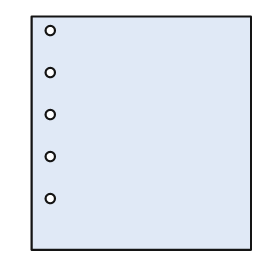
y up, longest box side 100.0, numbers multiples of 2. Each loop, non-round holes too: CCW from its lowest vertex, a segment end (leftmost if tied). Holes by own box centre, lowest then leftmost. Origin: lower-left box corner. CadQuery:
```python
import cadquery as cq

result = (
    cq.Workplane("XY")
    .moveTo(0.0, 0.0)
    .lineTo(94.0, 0.0)
    .lineTo(94.0, 100.0)
    .lineTo(0.0, 100.0)
    .close()
    .moveTo(8.0, 22.0)
    .circle(2.0)
    .moveTo(8.0, 40.0)
    .circle(2.0)
    .moveTo(8.0, 58.0)
    .circle(2.0)
    .moveTo(8.0, 76.0)
    .circle(2.0)
    .moveTo(8.0, 94.0)
    .circle(2.0)
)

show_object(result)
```